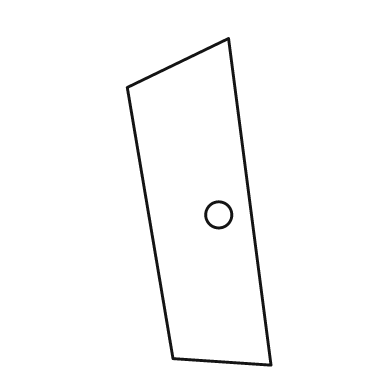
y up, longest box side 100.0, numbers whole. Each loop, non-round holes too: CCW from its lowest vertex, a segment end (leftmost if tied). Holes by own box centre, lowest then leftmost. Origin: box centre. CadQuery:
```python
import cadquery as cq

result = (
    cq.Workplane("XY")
    .moveTo(22.0, -50.0)
    .lineTo(9.0, 50.0)
    .lineTo(-22.0, 35.0)
    .lineTo(-8.0, -48.0)
    .close()
    .moveTo(6.0, -4.0)
    .circle(4.0)
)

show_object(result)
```